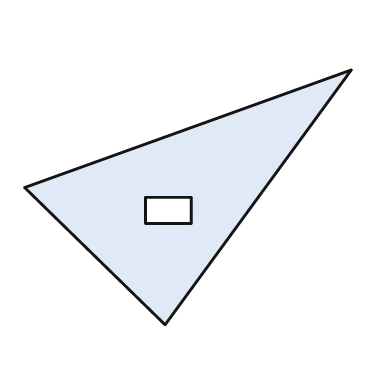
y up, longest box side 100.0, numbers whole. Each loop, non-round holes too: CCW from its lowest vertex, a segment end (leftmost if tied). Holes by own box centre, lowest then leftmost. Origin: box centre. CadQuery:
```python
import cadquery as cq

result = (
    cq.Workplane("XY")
    .moveTo(-7.0, -39.0)
    .lineTo(50.0, 39.0)
    .lineTo(-50.0, 3.0)
    .close()
    .moveTo(-13.0, -8.0)
    .lineTo(1.0, -8.0)
    .lineTo(1.0, 0.0)
    .lineTo(-13.0, 0.0)
    .close()
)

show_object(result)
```